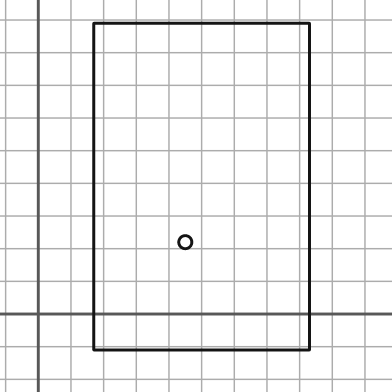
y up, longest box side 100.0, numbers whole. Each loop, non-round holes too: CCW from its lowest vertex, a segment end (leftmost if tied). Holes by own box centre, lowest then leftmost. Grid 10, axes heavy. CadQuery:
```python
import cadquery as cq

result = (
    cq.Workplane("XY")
    .moveTo(17.0, -11.0)
    .lineTo(83.0, -11.0)
    .lineTo(83.0, 89.0)
    .lineTo(17.0, 89.0)
    .close()
    .moveTo(45.0, 22.0)
    .circle(2.0)
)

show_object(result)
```